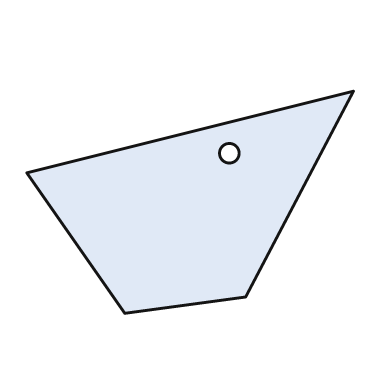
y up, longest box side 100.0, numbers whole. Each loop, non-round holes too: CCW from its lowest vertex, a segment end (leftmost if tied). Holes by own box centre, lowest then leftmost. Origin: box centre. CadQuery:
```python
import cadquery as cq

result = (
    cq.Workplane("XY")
    .moveTo(-20.0, -34.0)
    .lineTo(17.0, -29.0)
    .lineTo(50.0, 34.0)
    .lineTo(-50.0, 9.0)
    .close()
    .moveTo(12.0, 15.0)
    .circle(3.0)
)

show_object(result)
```